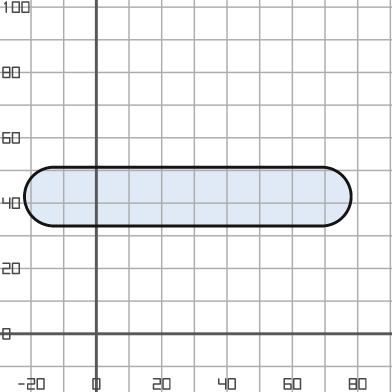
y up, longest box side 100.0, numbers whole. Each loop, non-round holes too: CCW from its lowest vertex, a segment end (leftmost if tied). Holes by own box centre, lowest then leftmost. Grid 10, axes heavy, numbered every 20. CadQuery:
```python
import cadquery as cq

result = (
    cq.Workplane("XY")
    .moveTo(-13.0, 33.0)
    .lineTo(69.0, 33.0)
    .threePointArc((78.0, 42.0), (69.0, 51.0))
    .lineTo(-13.0, 51.0)
    .threePointArc((-22.0, 42.0), (-13.0, 33.0))
    .close()
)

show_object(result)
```